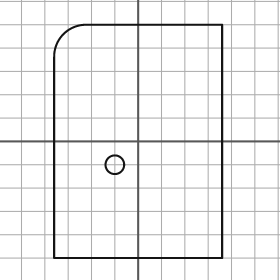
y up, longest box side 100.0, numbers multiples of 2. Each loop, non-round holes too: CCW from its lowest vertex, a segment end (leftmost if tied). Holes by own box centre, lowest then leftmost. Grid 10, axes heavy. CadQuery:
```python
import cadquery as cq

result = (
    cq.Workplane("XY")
    .moveTo(-36.0, -50.0)
    .lineTo(36.0, -50.0)
    .lineTo(36.0, 50.0)
    .lineTo(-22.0, 50.0)
    .threePointArc((-32.0, 46.0), (-36.0, 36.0))
    .close()
    .moveTo(-10.0, -10.0)
    .circle(4.0)
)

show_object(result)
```